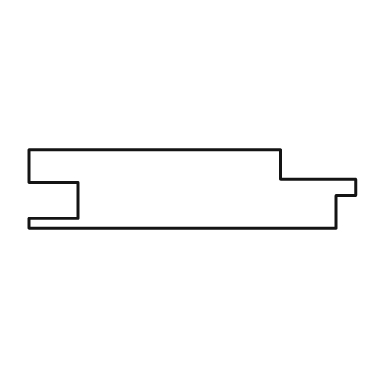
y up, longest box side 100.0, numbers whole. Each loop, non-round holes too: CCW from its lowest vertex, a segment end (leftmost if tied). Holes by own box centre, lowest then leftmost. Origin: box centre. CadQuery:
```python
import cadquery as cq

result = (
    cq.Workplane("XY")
    .moveTo(-50.0, -12.0)
    .lineTo(44.0, -12.0)
    .lineTo(44.0, -2.0)
    .lineTo(50.0, -2.0)
    .lineTo(50.0, 3.0)
    .lineTo(27.0, 3.0)
    .lineTo(27.0, 12.0)
    .lineTo(-50.0, 12.0)
    .lineTo(-50.0, 2.0)
    .lineTo(-35.0, 2.0)
    .lineTo(-35.0, -9.0)
    .lineTo(-50.0, -9.0)
    .close()
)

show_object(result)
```